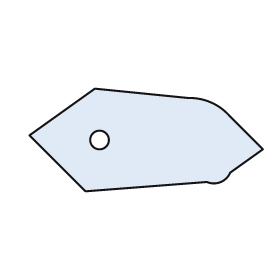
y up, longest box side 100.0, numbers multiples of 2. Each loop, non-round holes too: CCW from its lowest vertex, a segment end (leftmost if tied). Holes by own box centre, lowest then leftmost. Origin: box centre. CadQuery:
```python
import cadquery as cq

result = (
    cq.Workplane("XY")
    .moveTo(-26.0, -22.0)
    .lineTo(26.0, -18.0)
    .threePointArc((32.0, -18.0), (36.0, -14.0))
    .lineTo(50.0, -4.0)
    .lineTo(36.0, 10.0)
    .threePointArc((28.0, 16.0), (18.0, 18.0))
    .lineTo(-22.0, 22.0)
    .lineTo(-50.0, 2.0)
    .close()
    .moveTo(-20.0, 0.0)
    .circle(4.0)
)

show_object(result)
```